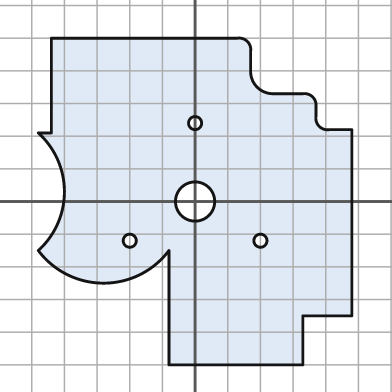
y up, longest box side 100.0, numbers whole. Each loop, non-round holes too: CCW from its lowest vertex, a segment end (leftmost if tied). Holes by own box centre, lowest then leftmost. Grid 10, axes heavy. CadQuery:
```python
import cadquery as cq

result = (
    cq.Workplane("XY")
    .moveTo(-8.0, -50.0)
    .lineTo(33.0, -50.0)
    .lineTo(33.0, -35.0)
    .lineTo(48.0, -35.0)
    .lineTo(48.0, 22.0)
    .lineTo(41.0, 22.0)
    .threePointArc((38.0, 23.0), (37.0, 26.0))
    .lineTo(37.0, 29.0)
    .threePointArc((36.0, 32.0), (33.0, 33.0))
    .lineTo(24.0, 33.0)
    .threePointArc((19.0, 35.0), (17.0, 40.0))
    .lineTo(17.0, 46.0)
    .threePointArc((16.0, 49.0), (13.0, 50.0))
    .lineTo(-44.0, 50.0)
    .lineTo(-44.0, 21.0)
    .lineTo(-48.0, 21.0)
    .threePointArc((-40.0, 3.0), (-48.0, -15.0))
    .threePointArc((-28.0, -25.0), (-8.0, -15.0))
    .close()
    .moveTo(-20.0, -12.0)
    .circle(2.0)
    .moveTo(20.0, -12.0)
    .circle(2.0)
    .moveTo(0.0, 0.0)
    .circle(6.0)
    .moveTo(0.0, 24.0)
    .circle(2.0)
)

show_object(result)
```